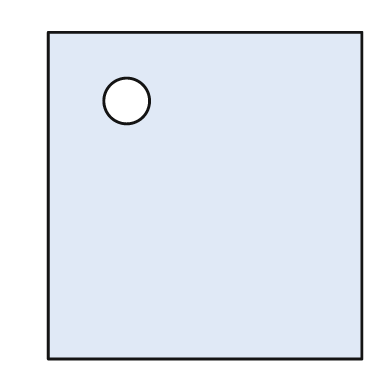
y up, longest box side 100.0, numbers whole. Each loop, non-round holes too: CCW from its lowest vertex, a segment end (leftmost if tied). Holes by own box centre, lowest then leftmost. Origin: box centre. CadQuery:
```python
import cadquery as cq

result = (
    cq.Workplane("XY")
    .moveTo(-48.0, -50.0)
    .lineTo(48.0, -50.0)
    .lineTo(48.0, 50.0)
    .lineTo(-48.0, 50.0)
    .close()
    .moveTo(-24.0, 29.0)
    .circle(7.0)
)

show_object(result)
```